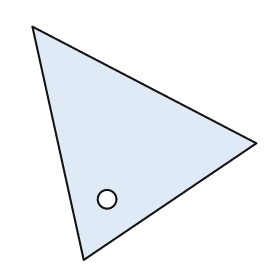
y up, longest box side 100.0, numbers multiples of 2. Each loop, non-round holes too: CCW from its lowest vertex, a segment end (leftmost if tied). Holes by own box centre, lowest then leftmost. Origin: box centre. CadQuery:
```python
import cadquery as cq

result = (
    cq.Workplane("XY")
    .moveTo(-26.0, -50.0)
    .lineTo(48.0, 0.0)
    .lineTo(-48.0, 50.0)
    .close()
    .moveTo(-16.0, -24.0)
    .circle(4.0)
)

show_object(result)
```